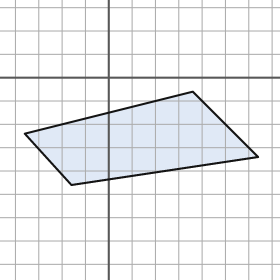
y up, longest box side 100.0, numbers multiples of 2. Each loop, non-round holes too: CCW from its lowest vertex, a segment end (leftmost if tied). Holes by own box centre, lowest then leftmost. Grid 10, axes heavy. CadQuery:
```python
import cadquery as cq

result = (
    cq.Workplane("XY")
    .moveTo(-16.0, -46.0)
    .lineTo(64.0, -34.0)
    .lineTo(36.0, -6.0)
    .lineTo(-36.0, -24.0)
    .close()
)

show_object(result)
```